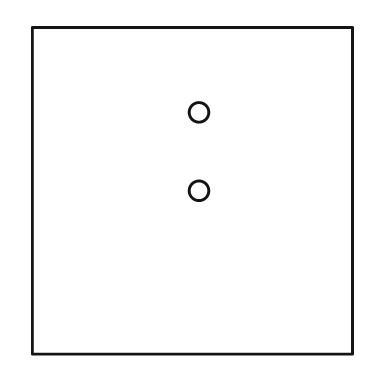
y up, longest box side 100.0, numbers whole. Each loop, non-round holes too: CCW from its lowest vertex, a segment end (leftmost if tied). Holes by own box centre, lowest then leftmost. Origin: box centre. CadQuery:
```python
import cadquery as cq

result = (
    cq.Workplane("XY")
    .moveTo(-49.0, -50.0)
    .lineTo(49.0, -50.0)
    .lineTo(49.0, 50.0)
    .lineTo(-49.0, 50.0)
    .close()
    .moveTo(2.0, 0.0)
    .circle(3.0)
    .moveTo(2.0, 24.0)
    .circle(3.0)
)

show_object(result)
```